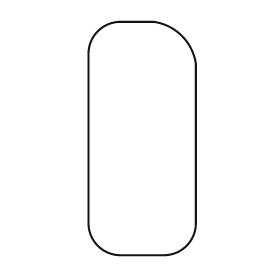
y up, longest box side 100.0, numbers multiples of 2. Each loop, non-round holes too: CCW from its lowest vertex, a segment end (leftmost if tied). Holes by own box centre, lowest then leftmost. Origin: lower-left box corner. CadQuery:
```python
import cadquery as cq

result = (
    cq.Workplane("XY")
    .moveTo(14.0, 0.0)
    .lineTo(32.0, 0.0)
    .threePointArc((42.0, 4.0), (46.0, 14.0))
    .lineTo(46.0, 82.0)
    .threePointArc((40.0, 94.0), (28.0, 100.0))
    .lineTo(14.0, 100.0)
    .threePointArc((4.0, 96.0), (0.0, 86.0))
    .lineTo(0.0, 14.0)
    .threePointArc((4.0, 4.0), (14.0, 0.0))
    .close()
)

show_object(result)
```